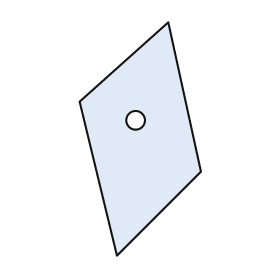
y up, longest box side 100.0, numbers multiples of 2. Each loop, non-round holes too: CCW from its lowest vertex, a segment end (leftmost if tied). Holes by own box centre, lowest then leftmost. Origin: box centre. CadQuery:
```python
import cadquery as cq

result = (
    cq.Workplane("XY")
    .moveTo(-10.0, -50.0)
    .lineTo(26.0, -14.0)
    .lineTo(12.0, 50.0)
    .lineTo(-26.0, 16.0)
    .close()
    .moveTo(-2.0, 8.0)
    .circle(4.0)
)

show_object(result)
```